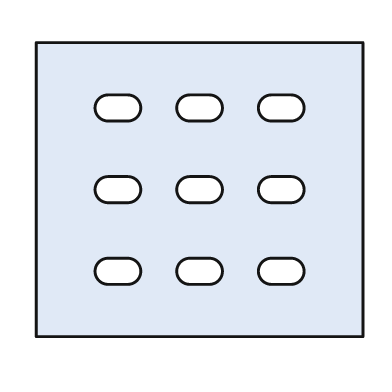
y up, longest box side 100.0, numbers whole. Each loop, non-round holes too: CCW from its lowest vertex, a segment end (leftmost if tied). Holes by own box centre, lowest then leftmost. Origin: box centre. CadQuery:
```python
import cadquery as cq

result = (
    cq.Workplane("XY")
    .moveTo(-50.0, -45.0)
    .lineTo(50.0, -45.0)
    .lineTo(50.0, 45.0)
    .lineTo(-50.0, 45.0)
    .close()
    .moveTo(-28.0, -29.0)
    .lineTo(-22.0, -29.0)
    .threePointArc((-18.0, -25.0), (-22.0, -21.0))
    .lineTo(-28.0, -21.0)
    .threePointArc((-32.0, -25.0), (-28.0, -29.0))
    .close()
    .moveTo(-3.0, -29.0)
    .lineTo(3.0, -29.0)
    .threePointArc((7.0, -25.0), (3.0, -21.0))
    .lineTo(-3.0, -21.0)
    .threePointArc((-7.0, -25.0), (-3.0, -29.0))
    .close()
    .moveTo(22.0, -29.0)
    .lineTo(28.0, -29.0)
    .threePointArc((32.0, -25.0), (28.0, -21.0))
    .lineTo(22.0, -21.0)
    .threePointArc((18.0, -25.0), (22.0, -29.0))
    .close()
    .moveTo(-28.0, -4.0)
    .lineTo(-22.0, -4.0)
    .threePointArc((-18.0, 0.0), (-22.0, 4.0))
    .lineTo(-28.0, 4.0)
    .threePointArc((-32.0, 0.0), (-28.0, -4.0))
    .close()
    .moveTo(-3.0, -4.0)
    .lineTo(3.0, -4.0)
    .threePointArc((7.0, 0.0), (3.0, 4.0))
    .lineTo(-3.0, 4.0)
    .threePointArc((-7.0, 0.0), (-3.0, -4.0))
    .close()
    .moveTo(22.0, -4.0)
    .lineTo(28.0, -4.0)
    .threePointArc((32.0, 0.0), (28.0, 4.0))
    .lineTo(22.0, 4.0)
    .threePointArc((18.0, 0.0), (22.0, -4.0))
    .close()
    .moveTo(-28.0, 21.0)
    .lineTo(-22.0, 21.0)
    .threePointArc((-18.0, 25.0), (-22.0, 29.0))
    .lineTo(-28.0, 29.0)
    .threePointArc((-32.0, 25.0), (-28.0, 21.0))
    .close()
    .moveTo(-3.0, 21.0)
    .lineTo(3.0, 21.0)
    .threePointArc((7.0, 25.0), (3.0, 29.0))
    .lineTo(-3.0, 29.0)
    .threePointArc((-7.0, 25.0), (-3.0, 21.0))
    .close()
    .moveTo(22.0, 21.0)
    .lineTo(28.0, 21.0)
    .threePointArc((32.0, 25.0), (28.0, 29.0))
    .lineTo(22.0, 29.0)
    .threePointArc((18.0, 25.0), (22.0, 21.0))
    .close()
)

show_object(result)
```